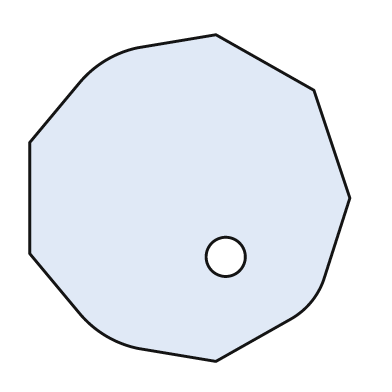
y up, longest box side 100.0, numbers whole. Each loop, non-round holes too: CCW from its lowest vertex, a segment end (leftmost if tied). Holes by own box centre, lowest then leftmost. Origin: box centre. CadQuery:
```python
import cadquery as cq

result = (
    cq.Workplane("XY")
    .moveTo(8.0, -50.0)
    .lineTo(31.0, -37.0)
    .threePointArc((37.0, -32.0), (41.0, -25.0))
    .lineTo(49.0, 0.0)
    .lineTo(38.0, 33.0)
    .lineTo(8.0, 50.0)
    .lineTo(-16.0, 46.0)
    .threePointArc((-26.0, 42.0), (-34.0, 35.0))
    .lineTo(-49.0, 17.0)
    .lineTo(-49.0, -17.0)
    .lineTo(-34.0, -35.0)
    .threePointArc((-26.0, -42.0), (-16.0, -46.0))
    .close()
    .moveTo(11.0, -18.0)
    .circle(6.0)
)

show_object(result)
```